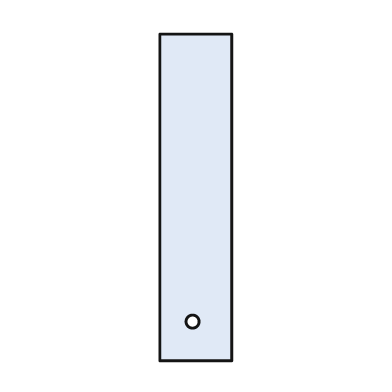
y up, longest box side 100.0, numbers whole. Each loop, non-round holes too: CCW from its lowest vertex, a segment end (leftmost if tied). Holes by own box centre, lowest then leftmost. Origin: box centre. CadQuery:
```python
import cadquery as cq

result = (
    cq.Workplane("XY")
    .moveTo(-11.0, -50.0)
    .lineTo(11.0, -50.0)
    .lineTo(11.0, 50.0)
    .lineTo(-11.0, 50.0)
    .close()
    .moveTo(-1.0, -38.0)
    .circle(2.0)
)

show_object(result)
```